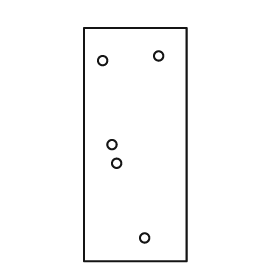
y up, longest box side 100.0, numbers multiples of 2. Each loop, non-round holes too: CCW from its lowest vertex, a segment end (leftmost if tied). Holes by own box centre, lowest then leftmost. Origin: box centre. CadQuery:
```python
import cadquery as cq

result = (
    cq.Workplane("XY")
    .moveTo(-22.0, -50.0)
    .lineTo(22.0, -50.0)
    .lineTo(22.0, 50.0)
    .lineTo(-22.0, 50.0)
    .close()
    .moveTo(4.0, -40.0)
    .circle(2.0)
    .moveTo(-8.0, -8.0)
    .circle(2.0)
    .moveTo(-10.0, 0.0)
    .circle(2.0)
    .moveTo(-14.0, 36.0)
    .circle(2.0)
    .moveTo(10.0, 38.0)
    .circle(2.0)
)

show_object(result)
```